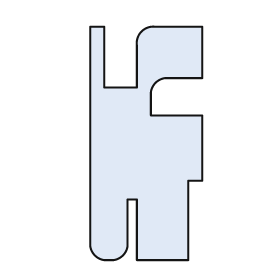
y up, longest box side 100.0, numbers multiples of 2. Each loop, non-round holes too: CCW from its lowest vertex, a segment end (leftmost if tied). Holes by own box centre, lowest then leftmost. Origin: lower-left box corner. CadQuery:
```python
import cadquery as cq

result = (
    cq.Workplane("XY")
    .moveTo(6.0, 0.0)
    .lineTo(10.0, 0.0)
    .threePointArc((14.0, 2.0), (16.0, 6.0))
    .lineTo(16.0, 26.0)
    .lineTo(20.0, 26.0)
    .lineTo(20.0, 0.0)
    .lineTo(42.0, 0.0)
    .lineTo(42.0, 34.0)
    .lineTo(48.0, 34.0)
    .lineTo(48.0, 62.0)
    .lineTo(26.0, 62.0)
    .lineTo(26.0, 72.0)
    .threePointArc((28.0, 76.0), (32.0, 78.0))
    .lineTo(48.0, 78.0)
    .lineTo(48.0, 100.0)
    .lineTo(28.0, 100.0)
    .threePointArc((22.0, 98.0), (20.0, 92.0))
    .lineTo(20.0, 74.0)
    .lineTo(6.0, 74.0)
    .lineTo(6.0, 100.0)
    .lineTo(0.0, 100.0)
    .lineTo(0.0, 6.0)
    .threePointArc((2.0, 2.0), (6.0, 0.0))
    .close()
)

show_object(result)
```